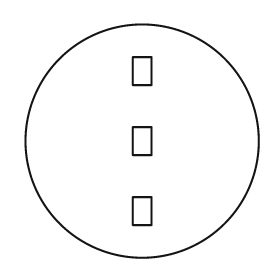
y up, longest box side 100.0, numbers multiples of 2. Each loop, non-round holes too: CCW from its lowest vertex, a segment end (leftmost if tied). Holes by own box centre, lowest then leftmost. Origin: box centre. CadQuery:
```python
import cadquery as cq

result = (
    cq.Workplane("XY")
    .moveTo(0.0, 0.0)
    .circle(50.0)
    .moveTo(-4.0, -36.0)
    .lineTo(4.0, -36.0)
    .lineTo(4.0, -24.0)
    .lineTo(-4.0, -24.0)
    .close()
    .moveTo(-4.0, -6.0)
    .lineTo(4.0, -6.0)
    .lineTo(4.0, 6.0)
    .lineTo(-4.0, 6.0)
    .close()
    .moveTo(-4.0, 24.0)
    .lineTo(4.0, 24.0)
    .lineTo(4.0, 36.0)
    .lineTo(-4.0, 36.0)
    .close()
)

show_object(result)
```